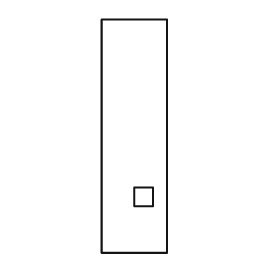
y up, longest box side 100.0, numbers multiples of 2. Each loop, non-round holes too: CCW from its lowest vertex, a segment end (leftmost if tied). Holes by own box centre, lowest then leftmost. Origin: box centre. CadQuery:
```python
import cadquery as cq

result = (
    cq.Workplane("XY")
    .moveTo(-14.0, -50.0)
    .lineTo(14.0, -50.0)
    .lineTo(14.0, 50.0)
    .lineTo(-14.0, 50.0)
    .close()
    .moveTo(0.0, -30.0)
    .lineTo(8.0, -30.0)
    .lineTo(8.0, -22.0)
    .lineTo(0.0, -22.0)
    .close()
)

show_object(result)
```